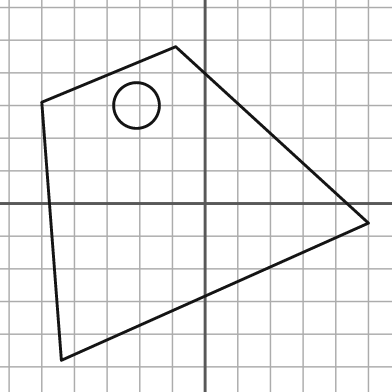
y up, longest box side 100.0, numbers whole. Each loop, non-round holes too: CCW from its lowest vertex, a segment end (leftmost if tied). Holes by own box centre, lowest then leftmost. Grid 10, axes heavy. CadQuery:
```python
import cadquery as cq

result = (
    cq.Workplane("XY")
    .moveTo(-44.0, -48.0)
    .lineTo(50.0, -6.0)
    .lineTo(-9.0, 48.0)
    .lineTo(-50.0, 31.0)
    .close()
    .moveTo(-21.0, 30.0)
    .circle(7.0)
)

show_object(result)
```